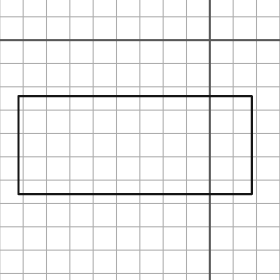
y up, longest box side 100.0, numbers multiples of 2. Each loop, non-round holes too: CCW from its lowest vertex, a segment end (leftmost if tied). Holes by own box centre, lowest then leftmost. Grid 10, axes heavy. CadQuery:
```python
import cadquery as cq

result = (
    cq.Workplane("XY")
    .moveTo(-82.0, -66.0)
    .lineTo(18.0, -66.0)
    .lineTo(18.0, -24.0)
    .lineTo(-82.0, -24.0)
    .close()
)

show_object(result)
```